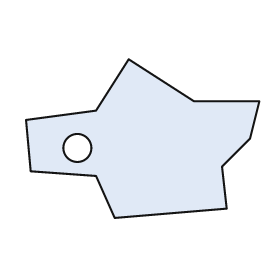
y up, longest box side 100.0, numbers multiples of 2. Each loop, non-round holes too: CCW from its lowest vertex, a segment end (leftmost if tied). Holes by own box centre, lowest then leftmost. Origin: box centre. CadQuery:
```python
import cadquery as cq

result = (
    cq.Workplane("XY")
    .moveTo(-12.0, -34.0)
    .lineTo(36.0, -30.0)
    .lineTo(34.0, -12.0)
    .lineTo(46.0, 0.0)
    .lineTo(50.0, 16.0)
    .lineTo(22.0, 16.0)
    .lineTo(-6.0, 34.0)
    .lineTo(-20.0, 12.0)
    .lineTo(-50.0, 8.0)
    .lineTo(-48.0, -14.0)
    .lineTo(-20.0, -16.0)
    .close()
    .moveTo(-28.0, -4.0)
    .circle(6.0)
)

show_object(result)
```